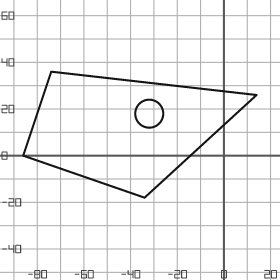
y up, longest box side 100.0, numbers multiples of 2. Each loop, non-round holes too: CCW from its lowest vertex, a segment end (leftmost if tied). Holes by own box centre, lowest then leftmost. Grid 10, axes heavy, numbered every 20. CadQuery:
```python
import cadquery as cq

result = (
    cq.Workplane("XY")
    .moveTo(-34.0, -18.0)
    .lineTo(14.0, 26.0)
    .lineTo(-74.0, 36.0)
    .lineTo(-86.0, 0.0)
    .close()
    .moveTo(-32.0, 18.0)
    .circle(6.0)
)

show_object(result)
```